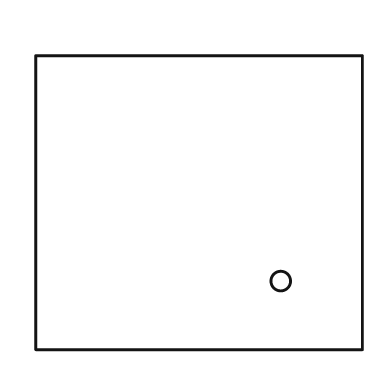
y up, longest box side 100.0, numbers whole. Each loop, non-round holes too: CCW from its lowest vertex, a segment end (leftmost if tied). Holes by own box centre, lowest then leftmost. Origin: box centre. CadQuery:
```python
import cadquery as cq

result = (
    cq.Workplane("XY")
    .moveTo(-50.0, -45.0)
    .lineTo(50.0, -45.0)
    .lineTo(50.0, 45.0)
    .lineTo(-50.0, 45.0)
    .close()
    .moveTo(25.0, -24.0)
    .circle(3.0)
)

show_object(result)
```